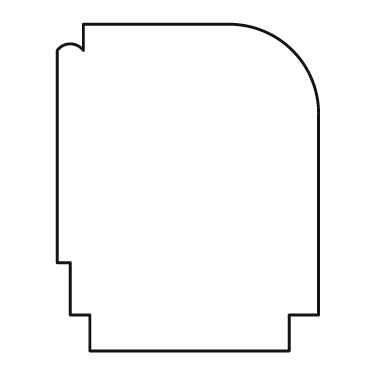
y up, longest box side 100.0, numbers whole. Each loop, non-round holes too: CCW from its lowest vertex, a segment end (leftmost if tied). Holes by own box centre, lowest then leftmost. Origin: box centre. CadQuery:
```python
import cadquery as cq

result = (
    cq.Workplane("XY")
    .moveTo(-30.0, -50.0)
    .lineTo(31.0, -50.0)
    .lineTo(31.0, -39.0)
    .lineTo(40.0, -39.0)
    .lineTo(40.0, 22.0)
    .threePointArc((32.0, 42.0), (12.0, 50.0))
    .lineTo(-32.0, 50.0)
    .lineTo(-32.0, 42.0)
    .threePointArc((-36.0, 44.0), (-40.0, 42.0))
    .lineTo(-40.0, -23.0)
    .lineTo(-36.0, -23.0)
    .lineTo(-36.0, -39.0)
    .lineTo(-30.0, -39.0)
    .close()
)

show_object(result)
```